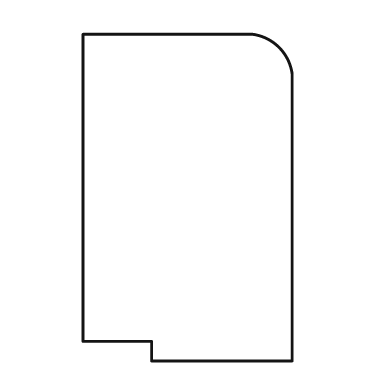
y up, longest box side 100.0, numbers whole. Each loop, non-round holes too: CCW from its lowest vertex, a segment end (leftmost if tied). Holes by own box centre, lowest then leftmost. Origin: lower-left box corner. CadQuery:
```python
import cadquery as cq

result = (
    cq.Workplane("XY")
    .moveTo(21.0, 0.0)
    .lineTo(64.0, 0.0)
    .lineTo(64.0, 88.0)
    .threePointArc((60.0, 96.0), (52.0, 100.0))
    .lineTo(0.0, 100.0)
    .lineTo(0.0, 6.0)
    .lineTo(21.0, 6.0)
    .close()
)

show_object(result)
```